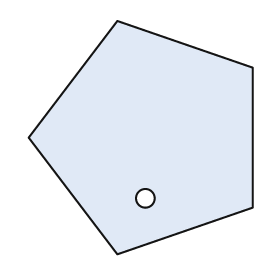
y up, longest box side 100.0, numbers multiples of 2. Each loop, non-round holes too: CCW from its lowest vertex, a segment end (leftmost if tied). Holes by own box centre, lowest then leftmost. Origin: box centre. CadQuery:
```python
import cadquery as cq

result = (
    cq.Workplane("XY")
    .moveTo(-10.0, -50.0)
    .lineTo(48.0, -30.0)
    .lineTo(48.0, 30.0)
    .lineTo(-10.0, 50.0)
    .lineTo(-48.0, 0.0)
    .close()
    .moveTo(2.0, -26.0)
    .circle(4.0)
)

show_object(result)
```